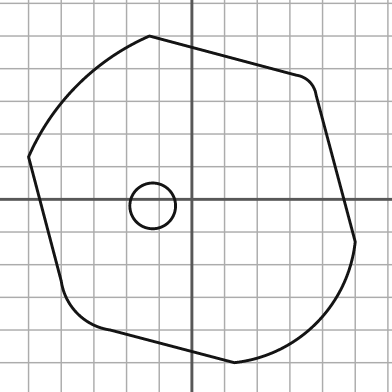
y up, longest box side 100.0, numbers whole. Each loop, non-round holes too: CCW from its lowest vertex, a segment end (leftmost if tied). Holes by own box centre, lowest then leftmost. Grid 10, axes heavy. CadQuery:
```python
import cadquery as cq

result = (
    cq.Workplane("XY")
    .moveTo(13.0, -50.0)
    .threePointArc((38.0, -38.0), (50.0, -13.0))
    .lineTo(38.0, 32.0)
    .threePointArc((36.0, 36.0), (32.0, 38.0))
    .lineTo(-13.0, 50.0)
    .threePointArc((-35.0, 35.0), (-50.0, 13.0))
    .lineTo(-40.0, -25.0)
    .threePointArc((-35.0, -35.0), (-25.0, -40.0))
    .close()
    .moveTo(-12.0, -2.0)
    .circle(7.0)
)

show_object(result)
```